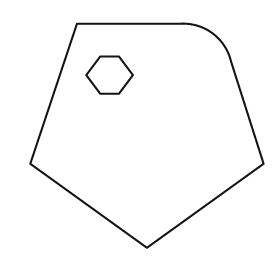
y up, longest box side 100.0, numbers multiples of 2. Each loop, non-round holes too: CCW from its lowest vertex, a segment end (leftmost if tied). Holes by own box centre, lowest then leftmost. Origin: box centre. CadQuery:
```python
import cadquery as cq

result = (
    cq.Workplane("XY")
    .moveTo(0.0, -48.0)
    .lineTo(50.0, -12.0)
    .lineTo(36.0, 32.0)
    .threePointArc((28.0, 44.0), (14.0, 48.0))
    .lineTo(-30.0, 48.0)
    .lineTo(-50.0, -12.0)
    .close()
    .moveTo(-20.0, 18.0)
    .lineTo(-12.0, 18.0)
    .lineTo(-6.0, 26.0)
    .lineTo(-12.0, 34.0)
    .lineTo(-20.0, 34.0)
    .lineTo(-26.0, 26.0)
    .close()
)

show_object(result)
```